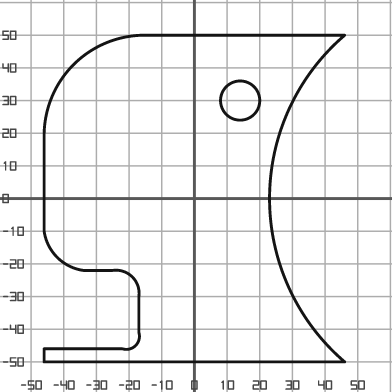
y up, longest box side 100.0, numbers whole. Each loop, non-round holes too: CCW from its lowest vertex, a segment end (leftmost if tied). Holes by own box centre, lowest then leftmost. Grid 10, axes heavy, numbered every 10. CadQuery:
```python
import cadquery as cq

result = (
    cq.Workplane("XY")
    .moveTo(-46.0, -50.0)
    .lineTo(46.0, -50.0)
    .threePointArc((23.0, 0.0), (46.0, 50.0))
    .lineTo(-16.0, 50.0)
    .threePointArc((-37.0, 41.0), (-46.0, 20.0))
    .lineTo(-46.0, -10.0)
    .threePointArc((-42.0, -18.0), (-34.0, -22.0))
    .lineTo(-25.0, -22.0)
    .threePointArc((-19.0, -24.0), (-17.0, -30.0))
    .lineTo(-17.0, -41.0)
    .threePointArc((-18.0, -45.0), (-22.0, -46.0))
    .lineTo(-46.0, -46.0)
    .close()
    .moveTo(14.0, 30.0)
    .circle(6.0)
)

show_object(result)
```